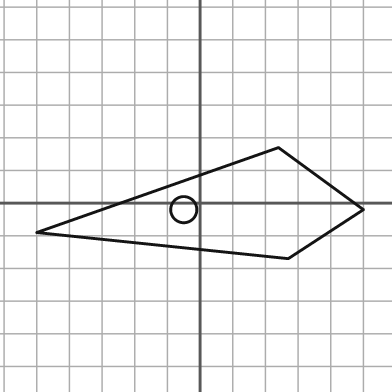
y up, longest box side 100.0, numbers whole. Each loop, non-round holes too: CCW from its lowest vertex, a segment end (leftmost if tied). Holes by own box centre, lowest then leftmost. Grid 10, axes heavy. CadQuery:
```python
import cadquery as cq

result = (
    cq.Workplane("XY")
    .moveTo(27.0, -17.0)
    .lineTo(50.0, -2.0)
    .lineTo(24.0, 17.0)
    .lineTo(-50.0, -9.0)
    .close()
    .moveTo(-5.0, -2.0)
    .circle(4.0)
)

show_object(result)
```